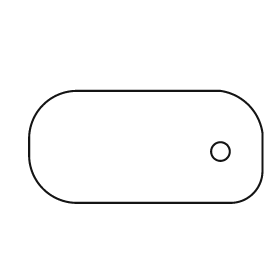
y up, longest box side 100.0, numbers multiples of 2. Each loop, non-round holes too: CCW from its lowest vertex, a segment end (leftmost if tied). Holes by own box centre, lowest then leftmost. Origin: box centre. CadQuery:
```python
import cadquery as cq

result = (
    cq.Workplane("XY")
    .moveTo(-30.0, -24.0)
    .lineTo(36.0, -24.0)
    .threePointArc((46.0, -20.0), (50.0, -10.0))
    .lineTo(50.0, 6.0)
    .threePointArc((44.0, 18.0), (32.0, 24.0))
    .lineTo(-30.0, 24.0)
    .threePointArc((-44.0, 18.0), (-50.0, 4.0))
    .lineTo(-50.0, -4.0)
    .threePointArc((-44.0, -18.0), (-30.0, -24.0))
    .close()
    .moveTo(32.0, -2.0)
    .circle(4.0)
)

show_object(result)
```